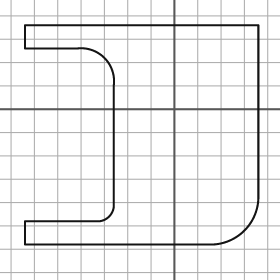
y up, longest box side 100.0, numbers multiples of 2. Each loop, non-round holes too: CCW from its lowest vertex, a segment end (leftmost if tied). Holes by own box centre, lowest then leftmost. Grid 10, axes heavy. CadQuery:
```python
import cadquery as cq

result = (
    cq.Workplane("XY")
    .moveTo(-64.0, -58.0)
    .lineTo(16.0, -58.0)
    .threePointArc((30.0, -52.0), (36.0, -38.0))
    .lineTo(36.0, 36.0)
    .lineTo(-64.0, 36.0)
    .lineTo(-64.0, 26.0)
    .lineTo(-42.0, 26.0)
    .threePointArc((-30.0, 22.0), (-26.0, 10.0))
    .lineTo(-26.0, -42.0)
    .threePointArc((-28.0, -46.0), (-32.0, -48.0))
    .lineTo(-64.0, -48.0)
    .close()
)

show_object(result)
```